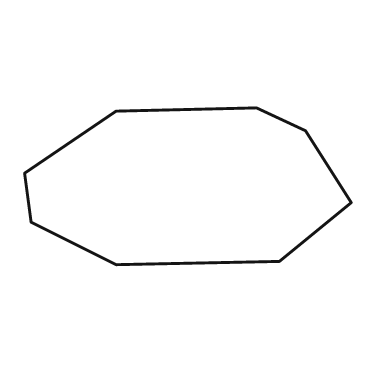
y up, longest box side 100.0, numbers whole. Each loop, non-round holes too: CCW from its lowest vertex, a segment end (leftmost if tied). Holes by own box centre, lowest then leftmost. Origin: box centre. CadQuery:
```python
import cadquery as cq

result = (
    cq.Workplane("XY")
    .moveTo(-22.0, -24.0)
    .lineTo(28.0, -23.0)
    .lineTo(50.0, -5.0)
    .lineTo(36.0, 17.0)
    .lineTo(21.0, 24.0)
    .lineTo(-22.0, 23.0)
    .lineTo(-50.0, 4.0)
    .lineTo(-48.0, -11.0)
    .close()
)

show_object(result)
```